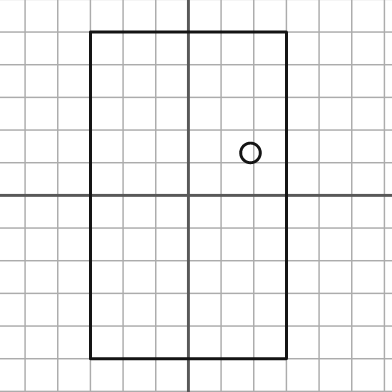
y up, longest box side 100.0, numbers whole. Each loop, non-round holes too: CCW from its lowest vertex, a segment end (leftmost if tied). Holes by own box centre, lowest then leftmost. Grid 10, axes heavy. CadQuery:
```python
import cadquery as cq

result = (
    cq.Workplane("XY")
    .moveTo(-30.0, -50.0)
    .lineTo(30.0, -50.0)
    .lineTo(30.0, 50.0)
    .lineTo(-30.0, 50.0)
    .close()
    .moveTo(19.0, 13.0)
    .circle(3.0)
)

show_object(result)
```